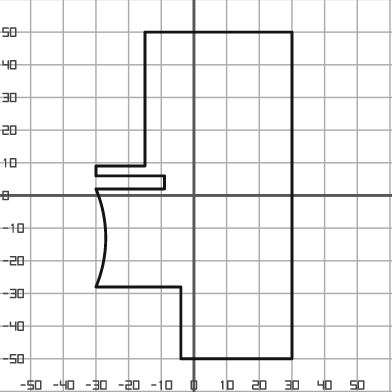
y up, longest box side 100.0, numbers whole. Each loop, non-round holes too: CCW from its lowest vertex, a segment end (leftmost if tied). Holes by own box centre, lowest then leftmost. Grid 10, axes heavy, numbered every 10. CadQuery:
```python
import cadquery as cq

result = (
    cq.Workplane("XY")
    .moveTo(-4.0, -50.0)
    .lineTo(30.0, -50.0)
    .lineTo(30.0, 50.0)
    .lineTo(-15.0, 50.0)
    .lineTo(-15.0, 9.0)
    .lineTo(-30.0, 9.0)
    .lineTo(-30.0, 6.0)
    .lineTo(-9.0, 6.0)
    .lineTo(-9.0, 2.0)
    .lineTo(-30.0, 2.0)
    .threePointArc((-27.0, -13.0), (-30.0, -28.0))
    .lineTo(-4.0, -28.0)
    .close()
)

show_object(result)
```